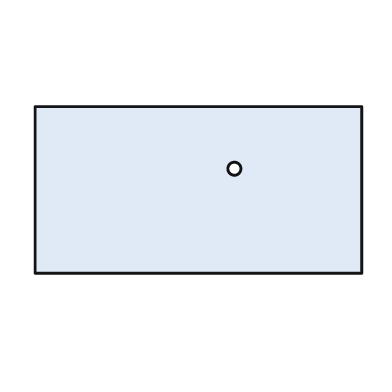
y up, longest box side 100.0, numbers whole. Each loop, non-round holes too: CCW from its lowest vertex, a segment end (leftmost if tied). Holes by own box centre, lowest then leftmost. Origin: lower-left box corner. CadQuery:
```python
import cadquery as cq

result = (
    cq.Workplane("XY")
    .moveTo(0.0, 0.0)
    .lineTo(100.0, 0.0)
    .lineTo(100.0, 51.0)
    .lineTo(0.0, 51.0)
    .close()
    .moveTo(61.0, 32.0)
    .circle(2.0)
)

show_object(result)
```